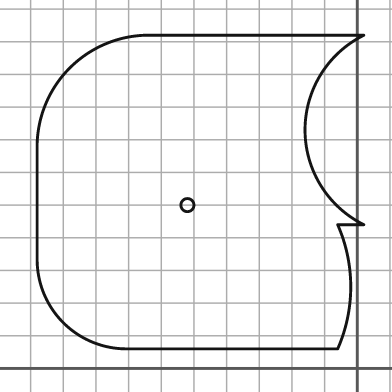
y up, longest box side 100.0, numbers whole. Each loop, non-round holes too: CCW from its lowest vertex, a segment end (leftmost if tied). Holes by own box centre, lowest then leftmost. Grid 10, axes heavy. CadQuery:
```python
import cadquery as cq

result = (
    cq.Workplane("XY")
    .moveTo(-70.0, 6.0)
    .lineTo(-6.0, 6.0)
    .threePointArc((-2.0, 25.0), (-6.0, 44.0))
    .lineTo(2.0, 44.0)
    .threePointArc((-16.0, 73.0), (2.0, 102.0))
    .lineTo(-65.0, 102.0)
    .threePointArc((-88.0, 92.0), (-98.0, 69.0))
    .lineTo(-98.0, 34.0)
    .threePointArc((-90.0, 14.0), (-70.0, 6.0))
    .close()
    .moveTo(-52.0, 50.0)
    .circle(2.0)
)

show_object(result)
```